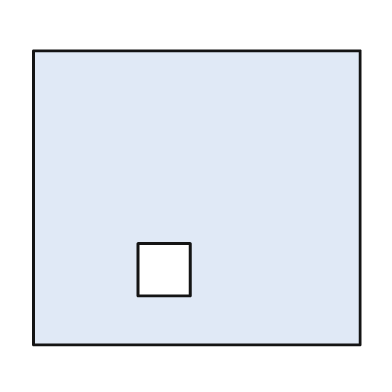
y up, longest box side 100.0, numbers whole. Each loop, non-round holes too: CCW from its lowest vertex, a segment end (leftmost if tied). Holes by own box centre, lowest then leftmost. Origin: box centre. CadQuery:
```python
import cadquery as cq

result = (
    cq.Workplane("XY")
    .moveTo(-50.0, -45.0)
    .lineTo(50.0, -45.0)
    .lineTo(50.0, 45.0)
    .lineTo(-50.0, 45.0)
    .close()
    .moveTo(-18.0, -30.0)
    .lineTo(-2.0, -30.0)
    .lineTo(-2.0, -14.0)
    .lineTo(-18.0, -14.0)
    .close()
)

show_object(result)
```